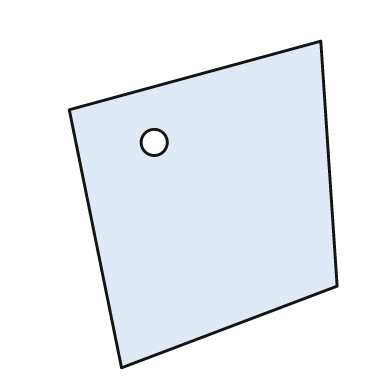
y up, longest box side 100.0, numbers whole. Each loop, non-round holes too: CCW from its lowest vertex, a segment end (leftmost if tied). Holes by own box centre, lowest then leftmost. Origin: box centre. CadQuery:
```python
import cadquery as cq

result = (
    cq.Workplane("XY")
    .moveTo(-25.0, -50.0)
    .lineTo(41.0, -25.0)
    .lineTo(36.0, 50.0)
    .lineTo(-41.0, 29.0)
    .close()
    .moveTo(-15.0, 19.0)
    .circle(4.0)
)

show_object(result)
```